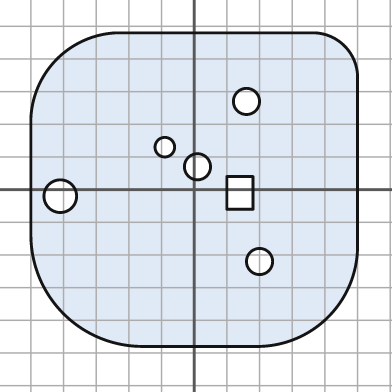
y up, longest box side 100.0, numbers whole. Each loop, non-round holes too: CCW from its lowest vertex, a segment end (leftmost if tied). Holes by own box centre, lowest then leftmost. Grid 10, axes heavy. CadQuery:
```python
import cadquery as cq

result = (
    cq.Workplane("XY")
    .moveTo(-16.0, -48.0)
    .lineTo(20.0, -48.0)
    .threePointArc((41.0, -39.0), (50.0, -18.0))
    .lineTo(50.0, 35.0)
    .threePointArc((46.0, 44.0), (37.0, 48.0))
    .lineTo(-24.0, 48.0)
    .threePointArc((-42.0, 40.0), (-50.0, 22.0))
    .lineTo(-50.0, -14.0)
    .threePointArc((-40.0, -38.0), (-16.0, -48.0))
    .close()
    .moveTo(20.0, -22.0)
    .circle(4.0)
    .moveTo(-41.0, -2.0)
    .circle(5.0)
    .moveTo(10.0, -6.0)
    .lineTo(18.0, -6.0)
    .lineTo(18.0, 4.0)
    .lineTo(10.0, 4.0)
    .close()
    .moveTo(1.0, 7.0)
    .circle(4.0)
    .moveTo(-9.0, 13.0)
    .circle(3.0)
    .moveTo(16.0, 27.0)
    .circle(4.0)
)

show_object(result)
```